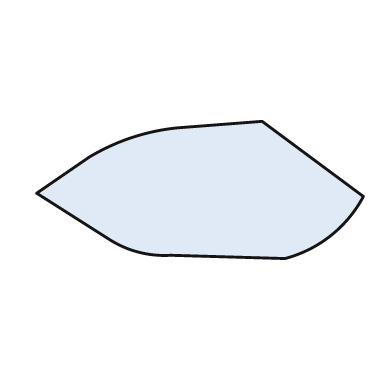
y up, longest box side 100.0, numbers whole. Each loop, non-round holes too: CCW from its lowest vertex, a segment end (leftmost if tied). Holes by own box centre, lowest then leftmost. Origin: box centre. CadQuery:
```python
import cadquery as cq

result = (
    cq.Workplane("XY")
    .moveTo(26.0, -21.0)
    .threePointArc((40.0, -14.0), (50.0, -2.0))
    .lineTo(19.0, 21.0)
    .lineTo(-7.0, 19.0)
    .threePointArc((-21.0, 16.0), (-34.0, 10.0))
    .lineTo(-50.0, -1.0)
    .lineTo(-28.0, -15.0)
    .threePointArc((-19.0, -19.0), (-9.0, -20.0))
    .close()
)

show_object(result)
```